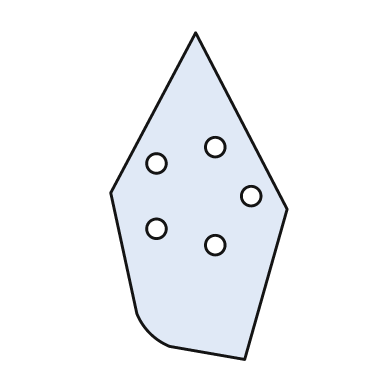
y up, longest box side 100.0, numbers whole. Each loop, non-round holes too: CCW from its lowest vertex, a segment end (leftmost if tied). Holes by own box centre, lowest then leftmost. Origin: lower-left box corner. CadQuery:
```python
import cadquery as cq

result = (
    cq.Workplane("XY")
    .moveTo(41.0, 0.0)
    .lineTo(54.0, 46.0)
    .lineTo(26.0, 100.0)
    .lineTo(0.0, 51.0)
    .lineTo(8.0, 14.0)
    .threePointArc((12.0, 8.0), (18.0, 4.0))
    .close()
    .moveTo(32.0, 35.0)
    .circle(3.0)
    .moveTo(14.0, 40.0)
    .circle(3.0)
    .moveTo(43.0, 50.0)
    .circle(3.0)
    .moveTo(14.0, 60.0)
    .circle(3.0)
    .moveTo(32.0, 65.0)
    .circle(3.0)
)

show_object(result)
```